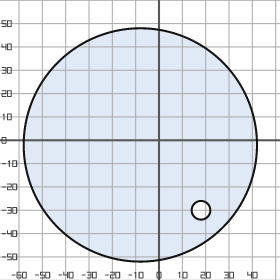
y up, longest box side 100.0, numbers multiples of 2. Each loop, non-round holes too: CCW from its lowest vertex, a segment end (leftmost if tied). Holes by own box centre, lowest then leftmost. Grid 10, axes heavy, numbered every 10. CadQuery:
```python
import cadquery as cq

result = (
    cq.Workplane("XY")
    .moveTo(-8.0, -2.0)
    .circle(50.0)
    .moveTo(18.0, -30.0)
    .circle(4.0)
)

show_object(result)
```